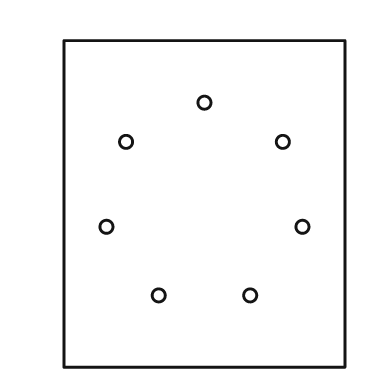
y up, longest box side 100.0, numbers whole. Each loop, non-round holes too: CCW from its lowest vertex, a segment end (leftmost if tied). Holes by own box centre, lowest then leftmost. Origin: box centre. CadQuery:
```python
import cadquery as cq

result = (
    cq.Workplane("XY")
    .moveTo(-43.0, -50.0)
    .lineTo(43.0, -50.0)
    .lineTo(43.0, 50.0)
    .lineTo(-43.0, 50.0)
    .close()
    .moveTo(-14.0, -28.0)
    .circle(2.0)
    .moveTo(14.0, -28.0)
    .circle(2.0)
    .moveTo(-30.0, -7.0)
    .circle(2.0)
    .moveTo(30.0, -7.0)
    .circle(2.0)
    .moveTo(-24.0, 19.0)
    .circle(2.0)
    .moveTo(24.0, 19.0)
    .circle(2.0)
    .moveTo(0.0, 31.0)
    .circle(2.0)
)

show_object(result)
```